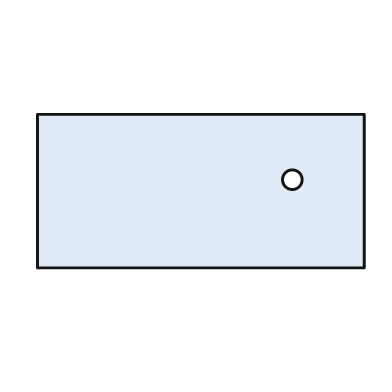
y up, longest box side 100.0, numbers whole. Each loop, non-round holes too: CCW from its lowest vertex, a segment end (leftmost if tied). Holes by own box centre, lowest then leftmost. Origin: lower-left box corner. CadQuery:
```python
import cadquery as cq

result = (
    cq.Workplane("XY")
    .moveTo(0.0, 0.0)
    .lineTo(100.0, 0.0)
    .lineTo(100.0, 47.0)
    .lineTo(0.0, 47.0)
    .close()
    .moveTo(78.0, 27.0)
    .circle(3.0)
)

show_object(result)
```